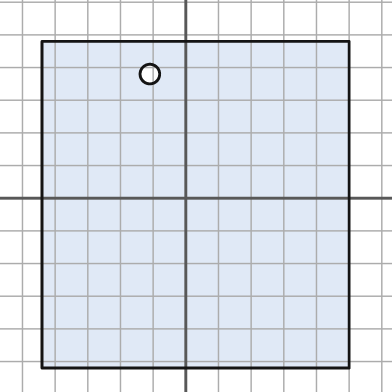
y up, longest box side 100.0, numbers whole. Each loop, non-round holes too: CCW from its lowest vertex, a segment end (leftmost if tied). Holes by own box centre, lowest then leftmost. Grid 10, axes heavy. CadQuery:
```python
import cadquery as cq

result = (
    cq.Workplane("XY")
    .moveTo(-44.0, -52.0)
    .lineTo(50.0, -52.0)
    .lineTo(50.0, 48.0)
    .lineTo(-44.0, 48.0)
    .close()
    .moveTo(-11.0, 38.0)
    .circle(3.0)
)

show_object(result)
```